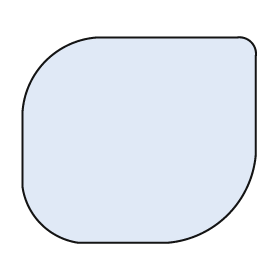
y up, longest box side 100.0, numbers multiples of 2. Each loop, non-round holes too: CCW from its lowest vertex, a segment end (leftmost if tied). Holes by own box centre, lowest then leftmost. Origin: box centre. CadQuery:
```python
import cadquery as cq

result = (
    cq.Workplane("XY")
    .moveTo(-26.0, -44.0)
    .lineTo(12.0, -44.0)
    .threePointArc((38.0, -32.0), (50.0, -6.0))
    .lineTo(50.0, 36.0)
    .threePointArc((48.0, 42.0), (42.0, 44.0))
    .lineTo(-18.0, 44.0)
    .threePointArc((-40.0, 34.0), (-50.0, 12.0))
    .lineTo(-50.0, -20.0)
    .threePointArc((-42.0, -36.0), (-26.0, -44.0))
    .close()
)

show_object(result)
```